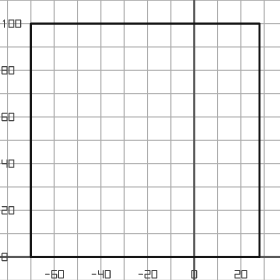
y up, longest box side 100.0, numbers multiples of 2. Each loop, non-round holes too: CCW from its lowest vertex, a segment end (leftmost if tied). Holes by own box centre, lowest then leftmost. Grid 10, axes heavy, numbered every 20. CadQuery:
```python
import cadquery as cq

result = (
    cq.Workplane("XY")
    .moveTo(-70.0, 0.0)
    .lineTo(28.0, 0.0)
    .lineTo(28.0, 100.0)
    .lineTo(-70.0, 100.0)
    .close()
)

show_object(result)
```